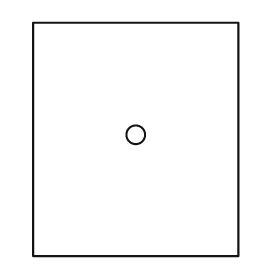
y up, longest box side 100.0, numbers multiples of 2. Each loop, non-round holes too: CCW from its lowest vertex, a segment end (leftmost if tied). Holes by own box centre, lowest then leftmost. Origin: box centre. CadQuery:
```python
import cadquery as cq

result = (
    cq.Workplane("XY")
    .moveTo(-44.0, -50.0)
    .lineTo(44.0, -50.0)
    .lineTo(44.0, 50.0)
    .lineTo(-44.0, 50.0)
    .close()
    .moveTo(0.0, 2.0)
    .circle(4.0)
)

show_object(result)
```